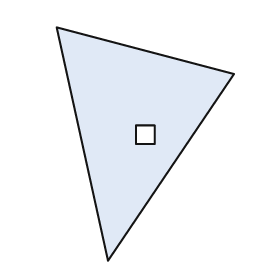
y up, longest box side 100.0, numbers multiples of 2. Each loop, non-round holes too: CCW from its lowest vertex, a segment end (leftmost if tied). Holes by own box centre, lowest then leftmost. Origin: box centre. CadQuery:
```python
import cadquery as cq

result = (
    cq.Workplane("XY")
    .moveTo(-16.0, -50.0)
    .lineTo(38.0, 30.0)
    .lineTo(-38.0, 50.0)
    .close()
    .moveTo(-4.0, 0.0)
    .lineTo(4.0, 0.0)
    .lineTo(4.0, 8.0)
    .lineTo(-4.0, 8.0)
    .close()
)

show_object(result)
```